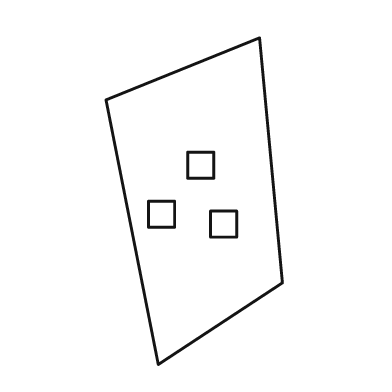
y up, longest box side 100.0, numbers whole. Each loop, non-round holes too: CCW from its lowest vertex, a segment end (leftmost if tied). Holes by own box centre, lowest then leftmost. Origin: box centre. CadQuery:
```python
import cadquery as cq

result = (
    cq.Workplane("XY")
    .moveTo(-11.0, -50.0)
    .lineTo(27.0, -25.0)
    .lineTo(20.0, 50.0)
    .lineTo(-27.0, 31.0)
    .close()
    .moveTo(5.0, -11.0)
    .lineTo(13.0, -11.0)
    .lineTo(13.0, -3.0)
    .lineTo(5.0, -3.0)
    .close()
    .moveTo(-14.0, -8.0)
    .lineTo(-6.0, -8.0)
    .lineTo(-6.0, 0.0)
    .lineTo(-14.0, 0.0)
    .close()
    .moveTo(-2.0, 7.0)
    .lineTo(6.0, 7.0)
    .lineTo(6.0, 15.0)
    .lineTo(-2.0, 15.0)
    .close()
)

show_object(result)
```